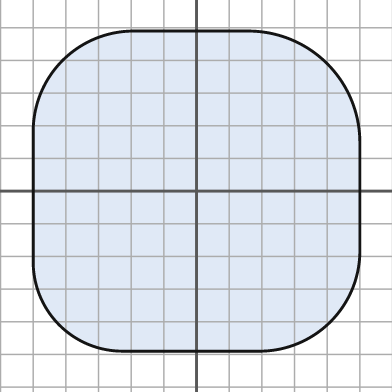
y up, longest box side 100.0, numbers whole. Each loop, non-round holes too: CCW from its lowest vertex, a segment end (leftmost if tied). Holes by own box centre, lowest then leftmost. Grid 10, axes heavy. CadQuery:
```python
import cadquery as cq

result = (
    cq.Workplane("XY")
    .moveTo(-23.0, -49.0)
    .lineTo(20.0, -49.0)
    .threePointArc((41.0, -40.0), (50.0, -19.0))
    .lineTo(50.0, 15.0)
    .threePointArc((40.0, 39.0), (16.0, 49.0))
    .lineTo(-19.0, 49.0)
    .threePointArc((-41.0, 40.0), (-50.0, 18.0))
    .lineTo(-50.0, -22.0)
    .threePointArc((-42.0, -41.0), (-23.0, -49.0))
    .close()
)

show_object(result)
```